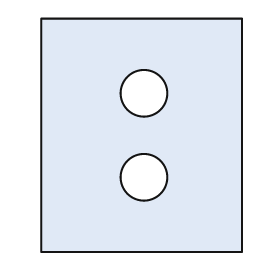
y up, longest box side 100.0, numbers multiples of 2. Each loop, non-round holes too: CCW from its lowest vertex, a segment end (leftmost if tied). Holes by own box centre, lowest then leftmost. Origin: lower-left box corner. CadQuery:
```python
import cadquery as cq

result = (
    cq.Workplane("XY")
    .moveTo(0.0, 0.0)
    .lineTo(86.0, 0.0)
    .lineTo(86.0, 100.0)
    .lineTo(0.0, 100.0)
    .close()
    .moveTo(44.0, 32.0)
    .circle(10.0)
    .moveTo(44.0, 68.0)
    .circle(10.0)
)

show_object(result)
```